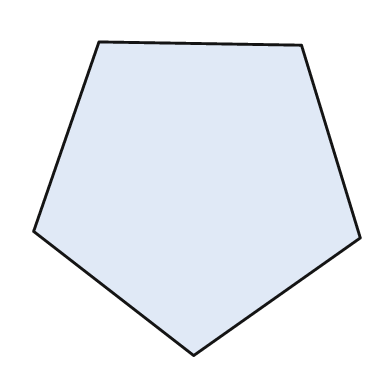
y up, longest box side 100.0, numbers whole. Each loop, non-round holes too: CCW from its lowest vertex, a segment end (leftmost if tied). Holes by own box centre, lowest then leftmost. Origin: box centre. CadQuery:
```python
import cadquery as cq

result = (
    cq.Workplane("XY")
    .moveTo(-1.0, -48.0)
    .lineTo(50.0, -12.0)
    .lineTo(32.0, 47.0)
    .lineTo(-30.0, 48.0)
    .lineTo(-50.0, -10.0)
    .close()
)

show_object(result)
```